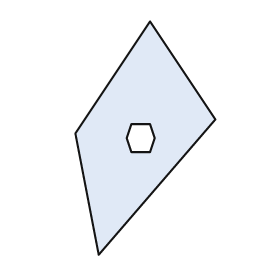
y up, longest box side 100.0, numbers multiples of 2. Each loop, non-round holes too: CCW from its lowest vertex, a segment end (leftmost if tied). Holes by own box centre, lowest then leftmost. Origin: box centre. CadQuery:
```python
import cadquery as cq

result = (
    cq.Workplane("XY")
    .moveTo(-20.0, -50.0)
    .lineTo(30.0, 8.0)
    .lineTo(2.0, 50.0)
    .lineTo(-30.0, 2.0)
    .close()
    .moveTo(-6.0, -6.0)
    .lineTo(2.0, -6.0)
    .lineTo(4.0, 0.0)
    .lineTo(2.0, 6.0)
    .lineTo(-6.0, 6.0)
    .lineTo(-8.0, 0.0)
    .close()
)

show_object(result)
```